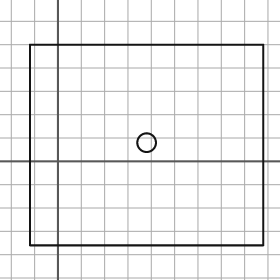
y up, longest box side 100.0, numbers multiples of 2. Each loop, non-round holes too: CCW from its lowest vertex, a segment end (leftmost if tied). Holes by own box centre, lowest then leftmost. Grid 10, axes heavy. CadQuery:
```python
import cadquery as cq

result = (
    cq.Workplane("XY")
    .moveTo(-12.0, -36.0)
    .lineTo(88.0, -36.0)
    .lineTo(88.0, 50.0)
    .lineTo(-12.0, 50.0)
    .close()
    .moveTo(38.0, 8.0)
    .circle(4.0)
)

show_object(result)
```